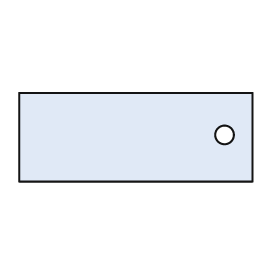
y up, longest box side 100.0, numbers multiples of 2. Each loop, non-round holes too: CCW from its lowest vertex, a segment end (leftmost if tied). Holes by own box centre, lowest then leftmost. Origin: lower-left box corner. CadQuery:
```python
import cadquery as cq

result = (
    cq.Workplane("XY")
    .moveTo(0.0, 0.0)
    .lineTo(100.0, 0.0)
    .lineTo(100.0, 38.0)
    .lineTo(0.0, 38.0)
    .close()
    .moveTo(88.0, 20.0)
    .circle(4.0)
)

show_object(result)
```